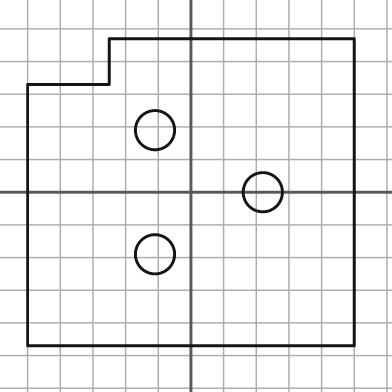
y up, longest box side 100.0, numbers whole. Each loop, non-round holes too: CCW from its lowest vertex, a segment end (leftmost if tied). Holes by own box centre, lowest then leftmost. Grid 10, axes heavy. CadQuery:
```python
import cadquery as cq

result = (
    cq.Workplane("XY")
    .moveTo(-50.0, -47.0)
    .lineTo(50.0, -47.0)
    .lineTo(50.0, 47.0)
    .lineTo(-25.0, 47.0)
    .lineTo(-25.0, 33.0)
    .lineTo(-50.0, 33.0)
    .close()
    .moveTo(-11.0, -19.0)
    .circle(6.0)
    .moveTo(22.0, 0.0)
    .circle(6.0)
    .moveTo(-11.0, 19.0)
    .circle(6.0)
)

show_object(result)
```